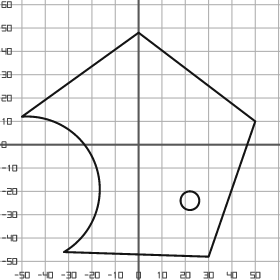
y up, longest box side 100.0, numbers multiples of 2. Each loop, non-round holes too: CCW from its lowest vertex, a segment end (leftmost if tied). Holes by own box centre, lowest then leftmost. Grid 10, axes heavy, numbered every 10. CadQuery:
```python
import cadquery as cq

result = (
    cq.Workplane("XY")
    .moveTo(30.0, -48.0)
    .lineTo(50.0, 10.0)
    .lineTo(0.0, 48.0)
    .lineTo(-50.0, 12.0)
    .threePointArc((-18.0, -10.0), (-32.0, -46.0))
    .close()
    .moveTo(22.0, -24.0)
    .circle(4.0)
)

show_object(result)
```